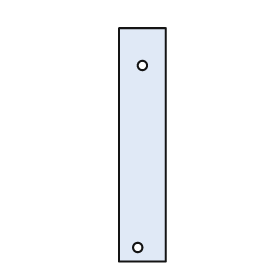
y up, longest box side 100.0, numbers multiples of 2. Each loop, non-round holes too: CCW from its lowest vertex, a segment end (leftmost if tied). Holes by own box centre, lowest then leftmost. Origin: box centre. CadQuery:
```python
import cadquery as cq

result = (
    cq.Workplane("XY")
    .moveTo(-10.0, -50.0)
    .lineTo(10.0, -50.0)
    .lineTo(10.0, 50.0)
    .lineTo(-10.0, 50.0)
    .close()
    .moveTo(-2.0, -44.0)
    .circle(2.0)
    .moveTo(0.0, 34.0)
    .circle(2.0)
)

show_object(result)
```